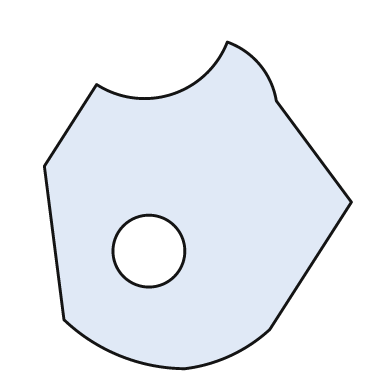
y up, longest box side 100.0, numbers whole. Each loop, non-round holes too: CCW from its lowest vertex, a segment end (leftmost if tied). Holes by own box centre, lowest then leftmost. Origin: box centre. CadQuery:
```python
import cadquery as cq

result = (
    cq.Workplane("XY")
    .moveTo(-4.0, -50.0)
    .threePointArc((10.0, -46.0), (22.0, -38.0))
    .lineTo(47.0, 1.0)
    .lineTo(24.0, 32.0)
    .threePointArc((19.0, 43.0), (9.0, 50.0))
    .threePointArc((-8.0, 34.0), (-31.0, 37.0))
    .lineTo(-47.0, 12.0)
    .lineTo(-41.0, -35.0)
    .threePointArc((-24.0, -46.0), (-4.0, -50.0))
    .close()
    .moveTo(-15.0, -14.0)
    .circle(11.0)
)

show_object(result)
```